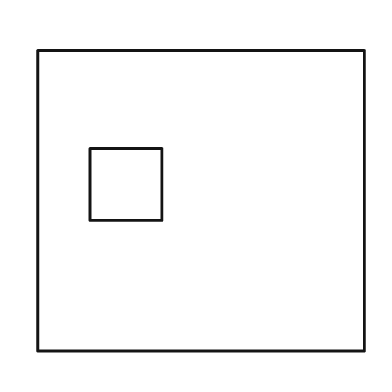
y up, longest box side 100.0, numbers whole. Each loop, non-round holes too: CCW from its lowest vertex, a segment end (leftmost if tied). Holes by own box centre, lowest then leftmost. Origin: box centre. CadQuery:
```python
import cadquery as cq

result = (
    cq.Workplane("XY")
    .moveTo(-50.0, -46.0)
    .lineTo(50.0, -46.0)
    .lineTo(50.0, 46.0)
    .lineTo(-50.0, 46.0)
    .close()
    .moveTo(-34.0, -6.0)
    .lineTo(-12.0, -6.0)
    .lineTo(-12.0, 16.0)
    .lineTo(-34.0, 16.0)
    .close()
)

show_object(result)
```